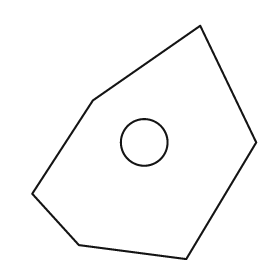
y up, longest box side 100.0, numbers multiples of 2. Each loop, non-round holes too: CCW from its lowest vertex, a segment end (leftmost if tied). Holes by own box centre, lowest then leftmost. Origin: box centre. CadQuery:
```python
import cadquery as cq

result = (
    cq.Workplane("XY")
    .moveTo(18.0, -50.0)
    .lineTo(48.0, 0.0)
    .lineTo(24.0, 50.0)
    .lineTo(-22.0, 18.0)
    .lineTo(-48.0, -22.0)
    .lineTo(-28.0, -44.0)
    .close()
    .moveTo(0.0, 0.0)
    .circle(10.0)
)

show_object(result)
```